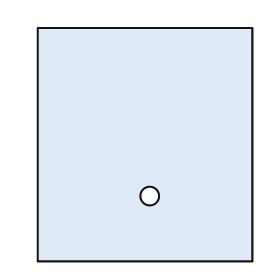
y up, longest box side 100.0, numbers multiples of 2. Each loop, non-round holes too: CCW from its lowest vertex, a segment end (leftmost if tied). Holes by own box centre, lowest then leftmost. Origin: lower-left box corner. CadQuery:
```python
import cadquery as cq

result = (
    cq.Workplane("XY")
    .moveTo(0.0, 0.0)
    .lineTo(92.0, 0.0)
    .lineTo(92.0, 100.0)
    .lineTo(0.0, 100.0)
    .close()
    .moveTo(48.0, 28.0)
    .circle(4.0)
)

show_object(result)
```